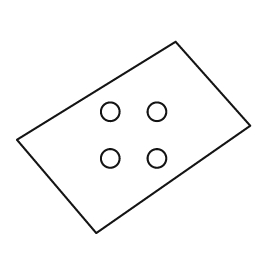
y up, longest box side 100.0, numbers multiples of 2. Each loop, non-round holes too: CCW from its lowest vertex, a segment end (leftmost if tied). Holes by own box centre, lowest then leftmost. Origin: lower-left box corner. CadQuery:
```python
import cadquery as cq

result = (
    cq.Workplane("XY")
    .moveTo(34.0, 0.0)
    .lineTo(100.0, 46.0)
    .lineTo(68.0, 82.0)
    .lineTo(0.0, 40.0)
    .close()
    .moveTo(40.0, 32.0)
    .circle(4.0)
    .moveTo(60.0, 32.0)
    .circle(4.0)
    .moveTo(40.0, 52.0)
    .circle(4.0)
    .moveTo(60.0, 52.0)
    .circle(4.0)
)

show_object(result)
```